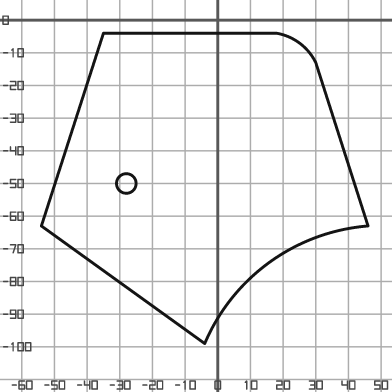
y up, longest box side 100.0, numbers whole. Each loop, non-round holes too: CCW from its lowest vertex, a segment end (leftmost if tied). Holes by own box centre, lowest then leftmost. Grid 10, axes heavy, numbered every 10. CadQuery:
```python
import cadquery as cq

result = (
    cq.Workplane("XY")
    .moveTo(-4.0, -99.0)
    .threePointArc((16.0, -74.0), (46.0, -63.0))
    .lineTo(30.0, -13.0)
    .threePointArc((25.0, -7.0), (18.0, -4.0))
    .lineTo(-35.0, -4.0)
    .lineTo(-54.0, -63.0)
    .close()
    .moveTo(-28.0, -50.0)
    .circle(3.0)
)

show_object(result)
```